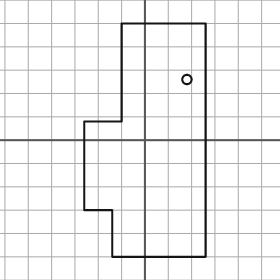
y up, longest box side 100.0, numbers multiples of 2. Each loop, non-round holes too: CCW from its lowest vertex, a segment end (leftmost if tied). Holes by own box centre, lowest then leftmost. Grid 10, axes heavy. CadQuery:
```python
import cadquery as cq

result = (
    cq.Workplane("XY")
    .moveTo(-14.0, -50.0)
    .lineTo(26.0, -50.0)
    .lineTo(26.0, 50.0)
    .lineTo(-10.0, 50.0)
    .lineTo(-10.0, 8.0)
    .lineTo(-26.0, 8.0)
    .lineTo(-26.0, -30.0)
    .lineTo(-14.0, -30.0)
    .close()
    .moveTo(18.0, 26.0)
    .circle(2.0)
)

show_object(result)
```